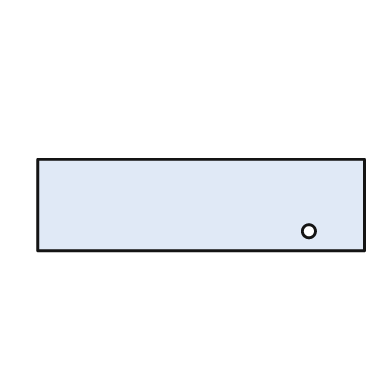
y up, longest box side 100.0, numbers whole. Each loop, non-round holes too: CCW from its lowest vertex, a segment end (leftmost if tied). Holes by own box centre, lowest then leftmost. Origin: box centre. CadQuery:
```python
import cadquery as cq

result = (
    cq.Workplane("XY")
    .moveTo(-50.0, -14.0)
    .lineTo(50.0, -14.0)
    .lineTo(50.0, 14.0)
    .lineTo(-50.0, 14.0)
    .close()
    .moveTo(33.0, -8.0)
    .circle(2.0)
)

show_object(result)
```